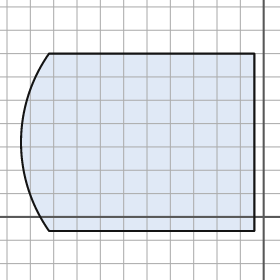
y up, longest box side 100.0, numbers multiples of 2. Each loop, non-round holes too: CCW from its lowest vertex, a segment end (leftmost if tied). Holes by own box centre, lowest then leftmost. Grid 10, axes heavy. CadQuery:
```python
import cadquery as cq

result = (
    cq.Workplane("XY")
    .moveTo(-92.0, -6.0)
    .lineTo(-4.0, -6.0)
    .lineTo(-4.0, 70.0)
    .lineTo(-92.0, 70.0)
    .threePointArc((-104.0, 32.0), (-92.0, -6.0))
    .close()
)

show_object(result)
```